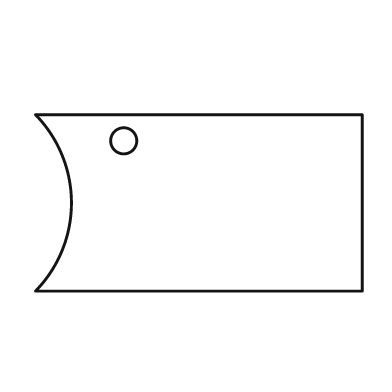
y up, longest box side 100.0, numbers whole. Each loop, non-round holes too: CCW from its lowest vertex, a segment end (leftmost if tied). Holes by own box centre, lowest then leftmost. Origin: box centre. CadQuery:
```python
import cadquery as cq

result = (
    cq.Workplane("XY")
    .moveTo(-50.0, -27.0)
    .lineTo(50.0, -27.0)
    .lineTo(50.0, 27.0)
    .lineTo(-50.0, 27.0)
    .threePointArc((-39.0, 0.0), (-50.0, -27.0))
    .close()
    .moveTo(-23.0, 19.0)
    .circle(4.0)
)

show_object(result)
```